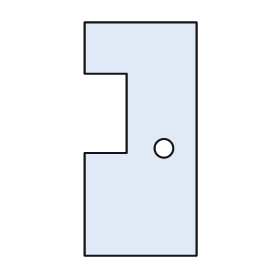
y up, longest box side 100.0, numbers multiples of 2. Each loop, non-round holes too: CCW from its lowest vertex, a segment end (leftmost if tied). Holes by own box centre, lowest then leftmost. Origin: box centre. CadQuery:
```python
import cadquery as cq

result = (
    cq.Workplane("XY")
    .moveTo(-24.0, -50.0)
    .lineTo(24.0, -50.0)
    .lineTo(24.0, 50.0)
    .lineTo(-24.0, 50.0)
    .lineTo(-24.0, 28.0)
    .lineTo(-6.0, 28.0)
    .lineTo(-6.0, -6.0)
    .lineTo(-24.0, -6.0)
    .close()
    .moveTo(10.0, -4.0)
    .circle(4.0)
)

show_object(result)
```